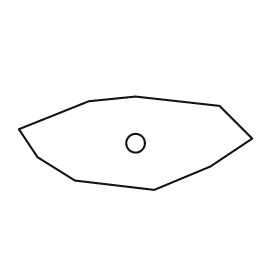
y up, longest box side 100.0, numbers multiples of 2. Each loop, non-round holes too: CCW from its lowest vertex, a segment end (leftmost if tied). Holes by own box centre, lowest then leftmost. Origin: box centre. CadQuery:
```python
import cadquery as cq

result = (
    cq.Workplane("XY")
    .moveTo(8.0, -20.0)
    .lineTo(32.0, -10.0)
    .lineTo(50.0, 2.0)
    .lineTo(36.0, 16.0)
    .lineTo(0.0, 20.0)
    .lineTo(-20.0, 18.0)
    .lineTo(-50.0, 6.0)
    .lineTo(-42.0, -6.0)
    .lineTo(-26.0, -16.0)
    .close()
    .moveTo(0.0, 0.0)
    .circle(4.0)
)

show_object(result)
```